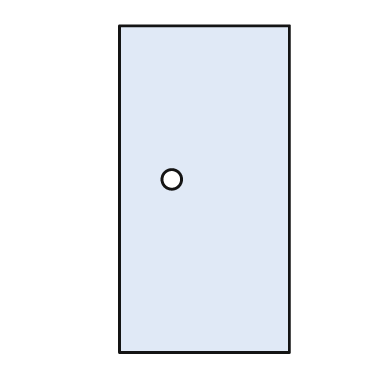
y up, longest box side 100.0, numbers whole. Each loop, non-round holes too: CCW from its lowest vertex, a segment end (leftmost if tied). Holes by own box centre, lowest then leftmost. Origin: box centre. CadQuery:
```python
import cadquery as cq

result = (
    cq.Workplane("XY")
    .moveTo(-26.0, -50.0)
    .lineTo(26.0, -50.0)
    .lineTo(26.0, 50.0)
    .lineTo(-26.0, 50.0)
    .close()
    .moveTo(-10.0, 3.0)
    .circle(3.0)
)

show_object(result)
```